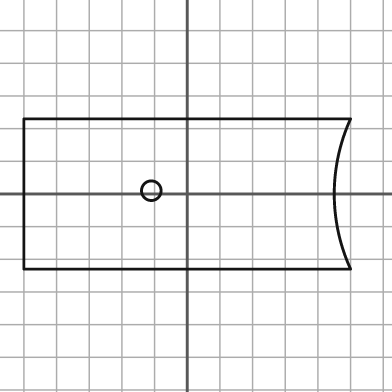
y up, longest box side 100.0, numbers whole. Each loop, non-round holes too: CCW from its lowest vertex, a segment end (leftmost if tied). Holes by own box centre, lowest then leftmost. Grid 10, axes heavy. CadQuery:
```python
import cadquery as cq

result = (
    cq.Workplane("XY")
    .moveTo(-50.0, -23.0)
    .lineTo(50.0, -23.0)
    .threePointArc((45.0, 0.0), (50.0, 23.0))
    .lineTo(-50.0, 23.0)
    .close()
    .moveTo(-11.0, 1.0)
    .circle(3.0)
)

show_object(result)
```